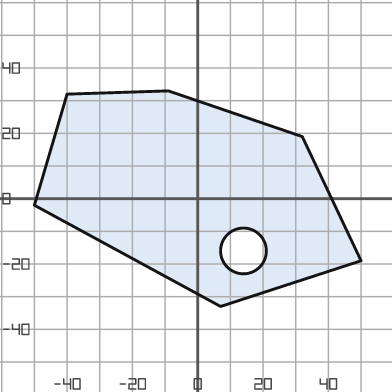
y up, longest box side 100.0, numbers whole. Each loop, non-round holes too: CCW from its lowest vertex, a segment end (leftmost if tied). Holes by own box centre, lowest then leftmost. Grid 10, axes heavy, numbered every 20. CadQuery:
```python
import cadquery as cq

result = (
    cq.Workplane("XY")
    .moveTo(7.0, -33.0)
    .lineTo(50.0, -19.0)
    .lineTo(32.0, 19.0)
    .lineTo(-9.0, 33.0)
    .lineTo(-40.0, 32.0)
    .lineTo(-50.0, -2.0)
    .close()
    .moveTo(14.0, -16.0)
    .circle(7.0)
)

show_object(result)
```